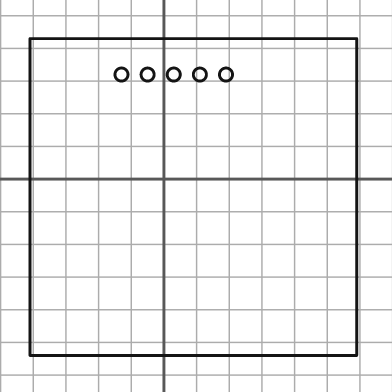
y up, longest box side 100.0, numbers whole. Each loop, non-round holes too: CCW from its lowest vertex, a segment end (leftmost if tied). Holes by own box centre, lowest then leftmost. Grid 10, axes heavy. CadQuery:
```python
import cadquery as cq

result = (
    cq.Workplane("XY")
    .moveTo(-41.0, -54.0)
    .lineTo(59.0, -54.0)
    .lineTo(59.0, 43.0)
    .lineTo(-41.0, 43.0)
    .close()
    .moveTo(-13.0, 32.0)
    .circle(2.0)
    .moveTo(-5.0, 32.0)
    .circle(2.0)
    .moveTo(3.0, 32.0)
    .circle(2.0)
    .moveTo(11.0, 32.0)
    .circle(2.0)
    .moveTo(19.0, 32.0)
    .circle(2.0)
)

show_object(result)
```